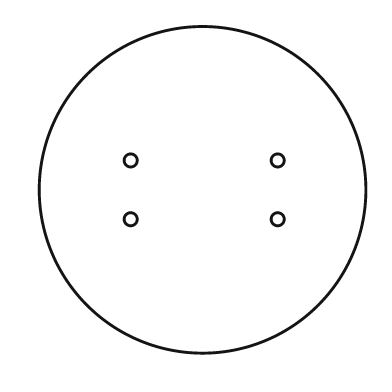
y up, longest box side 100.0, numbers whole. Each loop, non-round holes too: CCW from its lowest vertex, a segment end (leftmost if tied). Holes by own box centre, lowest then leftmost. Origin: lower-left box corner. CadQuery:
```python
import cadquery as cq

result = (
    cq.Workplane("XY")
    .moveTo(50.0, 50.0)
    .circle(50.0)
    .moveTo(28.0, 41.0)
    .circle(2.0)
    .moveTo(73.0, 41.0)
    .circle(2.0)
    .moveTo(28.0, 59.0)
    .circle(2.0)
    .moveTo(73.0, 59.0)
    .circle(2.0)
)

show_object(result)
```